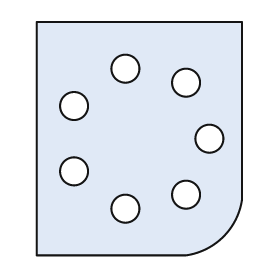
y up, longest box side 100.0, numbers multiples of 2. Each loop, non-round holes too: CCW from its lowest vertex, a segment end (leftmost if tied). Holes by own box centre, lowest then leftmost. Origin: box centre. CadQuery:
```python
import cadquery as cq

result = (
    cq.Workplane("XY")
    .moveTo(-44.0, -50.0)
    .lineTo(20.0, -50.0)
    .threePointArc((36.0, -42.0), (44.0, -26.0))
    .lineTo(44.0, 50.0)
    .lineTo(-44.0, 50.0)
    .close()
    .moveTo(-6.0, -30.0)
    .circle(6.0)
    .moveTo(20.0, -24.0)
    .circle(6.0)
    .moveTo(-28.0, -14.0)
    .circle(6.0)
    .moveTo(30.0, 0.0)
    .circle(6.0)
    .moveTo(-28.0, 14.0)
    .circle(6.0)
    .moveTo(20.0, 24.0)
    .circle(6.0)
    .moveTo(-6.0, 30.0)
    .circle(6.0)
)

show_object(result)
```